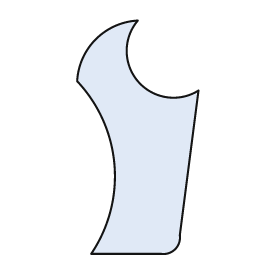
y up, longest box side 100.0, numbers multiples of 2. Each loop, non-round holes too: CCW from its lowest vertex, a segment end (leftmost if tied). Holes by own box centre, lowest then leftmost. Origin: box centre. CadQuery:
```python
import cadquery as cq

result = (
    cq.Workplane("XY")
    .moveTo(-20.0, -50.0)
    .lineTo(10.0, -50.0)
    .threePointArc((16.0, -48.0), (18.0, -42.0))
    .lineTo(26.0, 20.0)
    .threePointArc((0.0, 24.0), (0.0, 50.0))
    .threePointArc((-18.0, 42.0), (-26.0, 24.0))
    .threePointArc((-10.0, -12.0), (-20.0, -50.0))
    .close()
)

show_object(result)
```